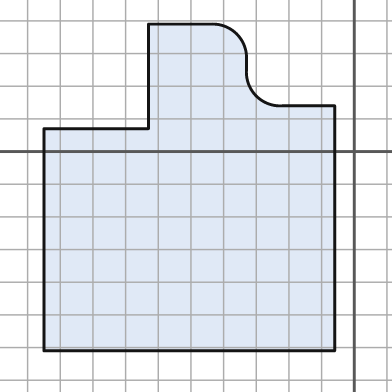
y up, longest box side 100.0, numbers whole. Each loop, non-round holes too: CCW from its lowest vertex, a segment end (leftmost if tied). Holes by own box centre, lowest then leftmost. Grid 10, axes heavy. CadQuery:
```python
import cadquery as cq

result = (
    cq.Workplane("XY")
    .moveTo(-95.0, -61.0)
    .lineTo(-6.0, -61.0)
    .lineTo(-6.0, 14.0)
    .lineTo(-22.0, 14.0)
    .threePointArc((-30.0, 17.0), (-33.0, 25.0))
    .lineTo(-33.0, 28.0)
    .threePointArc((-36.0, 36.0), (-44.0, 39.0))
    .lineTo(-63.0, 39.0)
    .lineTo(-63.0, 7.0)
    .lineTo(-95.0, 7.0)
    .close()
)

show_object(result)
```